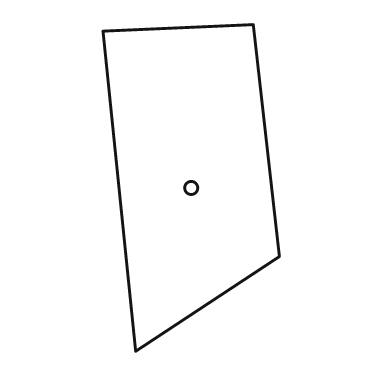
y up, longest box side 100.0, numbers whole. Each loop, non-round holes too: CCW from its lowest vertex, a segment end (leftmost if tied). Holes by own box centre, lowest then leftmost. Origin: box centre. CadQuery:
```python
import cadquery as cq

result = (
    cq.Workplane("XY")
    .moveTo(-17.0, -50.0)
    .lineTo(27.0, -21.0)
    .lineTo(19.0, 50.0)
    .lineTo(-27.0, 48.0)
    .close()
    .moveTo(0.0, 0.0)
    .circle(2.0)
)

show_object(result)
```